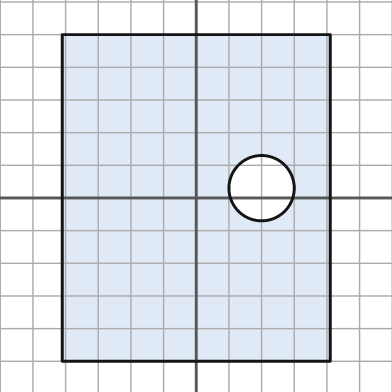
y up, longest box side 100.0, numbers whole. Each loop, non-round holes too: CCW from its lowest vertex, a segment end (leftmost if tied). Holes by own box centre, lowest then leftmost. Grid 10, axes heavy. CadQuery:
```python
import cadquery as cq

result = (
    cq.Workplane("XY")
    .moveTo(-41.0, -50.0)
    .lineTo(41.0, -50.0)
    .lineTo(41.0, 50.0)
    .lineTo(-41.0, 50.0)
    .close()
    .moveTo(20.0, 3.0)
    .circle(10.0)
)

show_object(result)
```